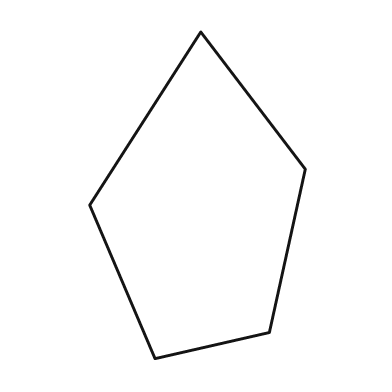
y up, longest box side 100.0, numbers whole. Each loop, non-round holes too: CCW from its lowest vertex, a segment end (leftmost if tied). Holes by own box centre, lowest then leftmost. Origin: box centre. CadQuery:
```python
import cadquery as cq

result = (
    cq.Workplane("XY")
    .moveTo(-13.0, -50.0)
    .lineTo(22.0, -42.0)
    .lineTo(33.0, 8.0)
    .lineTo(1.0, 50.0)
    .lineTo(-33.0, -3.0)
    .close()
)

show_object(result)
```